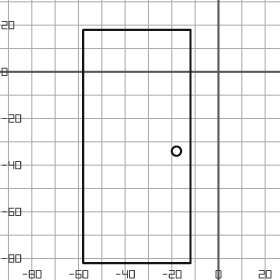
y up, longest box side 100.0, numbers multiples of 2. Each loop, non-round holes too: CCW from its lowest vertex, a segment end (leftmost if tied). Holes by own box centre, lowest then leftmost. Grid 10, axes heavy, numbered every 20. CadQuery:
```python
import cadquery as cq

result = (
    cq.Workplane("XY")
    .moveTo(-58.0, -82.0)
    .lineTo(-12.0, -82.0)
    .lineTo(-12.0, 18.0)
    .lineTo(-58.0, 18.0)
    .close()
    .moveTo(-18.0, -34.0)
    .circle(2.0)
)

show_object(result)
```